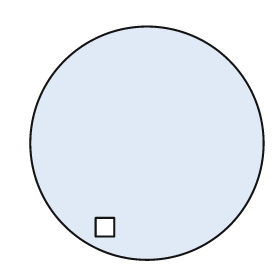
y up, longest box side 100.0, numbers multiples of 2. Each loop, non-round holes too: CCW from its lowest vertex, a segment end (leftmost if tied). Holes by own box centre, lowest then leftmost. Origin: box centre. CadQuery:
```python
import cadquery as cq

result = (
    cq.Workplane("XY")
    .moveTo(0.0, 0.0)
    .circle(50.0)
    .moveTo(-22.0, -40.0)
    .lineTo(-14.0, -40.0)
    .lineTo(-14.0, -32.0)
    .lineTo(-22.0, -32.0)
    .close()
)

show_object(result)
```